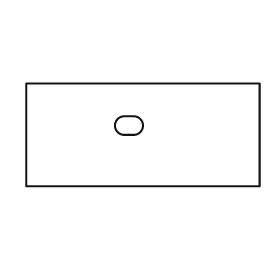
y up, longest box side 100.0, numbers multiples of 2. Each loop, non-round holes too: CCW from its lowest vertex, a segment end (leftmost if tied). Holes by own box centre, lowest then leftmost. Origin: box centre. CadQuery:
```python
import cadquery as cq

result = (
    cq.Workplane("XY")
    .moveTo(-50.0, -22.0)
    .lineTo(50.0, -22.0)
    .lineTo(50.0, 22.0)
    .lineTo(-50.0, 22.0)
    .close()
    .moveTo(-8.0, 0.0)
    .lineTo(-4.0, 0.0)
    .threePointArc((0.0, 4.0), (-4.0, 8.0))
    .lineTo(-8.0, 8.0)
    .threePointArc((-12.0, 4.0), (-8.0, 0.0))
    .close()
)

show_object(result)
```